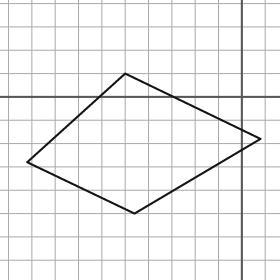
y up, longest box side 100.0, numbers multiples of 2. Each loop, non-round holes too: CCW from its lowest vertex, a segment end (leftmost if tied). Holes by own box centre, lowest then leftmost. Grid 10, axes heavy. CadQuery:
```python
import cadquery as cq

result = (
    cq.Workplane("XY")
    .moveTo(-46.0, -50.0)
    .lineTo(8.0, -18.0)
    .lineTo(-50.0, 10.0)
    .lineTo(-92.0, -28.0)
    .close()
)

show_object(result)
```